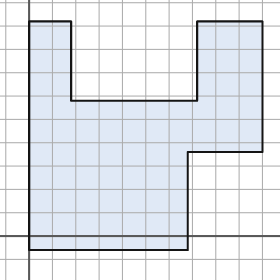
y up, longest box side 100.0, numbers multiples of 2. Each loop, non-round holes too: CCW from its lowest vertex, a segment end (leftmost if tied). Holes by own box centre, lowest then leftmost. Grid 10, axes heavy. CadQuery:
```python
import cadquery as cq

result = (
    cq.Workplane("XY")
    .moveTo(0.0, -6.0)
    .lineTo(68.0, -6.0)
    .lineTo(68.0, 36.0)
    .lineTo(100.0, 36.0)
    .lineTo(100.0, 92.0)
    .lineTo(72.0, 92.0)
    .lineTo(72.0, 58.0)
    .lineTo(18.0, 58.0)
    .lineTo(18.0, 92.0)
    .lineTo(0.0, 92.0)
    .close()
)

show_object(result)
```